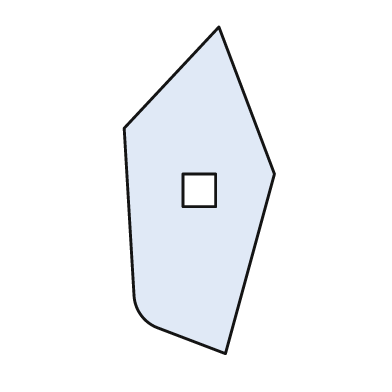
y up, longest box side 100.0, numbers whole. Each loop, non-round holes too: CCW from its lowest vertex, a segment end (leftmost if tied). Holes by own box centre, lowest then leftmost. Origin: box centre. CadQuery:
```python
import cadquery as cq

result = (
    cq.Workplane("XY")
    .moveTo(8.0, -50.0)
    .lineTo(23.0, 5.0)
    .lineTo(6.0, 50.0)
    .lineTo(-23.0, 19.0)
    .lineTo(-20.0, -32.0)
    .threePointArc((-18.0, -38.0), (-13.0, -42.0))
    .close()
    .moveTo(-5.0, -5.0)
    .lineTo(5.0, -5.0)
    .lineTo(5.0, 5.0)
    .lineTo(-5.0, 5.0)
    .close()
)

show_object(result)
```